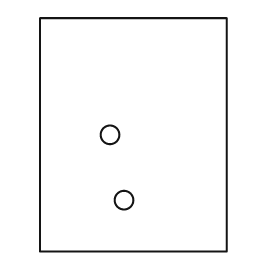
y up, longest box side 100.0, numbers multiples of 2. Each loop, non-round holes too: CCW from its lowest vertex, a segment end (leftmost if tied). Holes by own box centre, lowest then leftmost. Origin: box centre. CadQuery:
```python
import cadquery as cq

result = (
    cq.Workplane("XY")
    .moveTo(-40.0, -50.0)
    .lineTo(40.0, -50.0)
    .lineTo(40.0, 50.0)
    .lineTo(-40.0, 50.0)
    .close()
    .moveTo(-4.0, -28.0)
    .circle(4.0)
    .moveTo(-10.0, 0.0)
    .circle(4.0)
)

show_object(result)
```